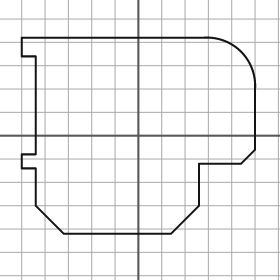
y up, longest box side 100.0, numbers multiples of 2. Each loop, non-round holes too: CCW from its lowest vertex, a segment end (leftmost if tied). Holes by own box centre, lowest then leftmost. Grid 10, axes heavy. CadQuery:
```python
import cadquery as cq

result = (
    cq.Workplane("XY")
    .moveTo(-32.0, -42.0)
    .lineTo(14.0, -42.0)
    .lineTo(26.0, -30.0)
    .lineTo(26.0, -12.0)
    .lineTo(44.0, -12.0)
    .lineTo(50.0, -6.0)
    .lineTo(50.0, 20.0)
    .threePointArc((44.0, 36.0), (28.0, 42.0))
    .lineTo(-50.0, 42.0)
    .lineTo(-50.0, 34.0)
    .lineTo(-44.0, 34.0)
    .lineTo(-44.0, -8.0)
    .lineTo(-50.0, -8.0)
    .lineTo(-50.0, -14.0)
    .lineTo(-44.0, -14.0)
    .lineTo(-44.0, -30.0)
    .close()
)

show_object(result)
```